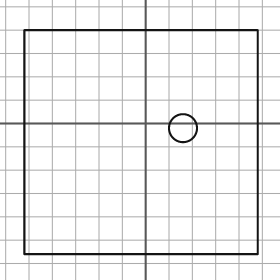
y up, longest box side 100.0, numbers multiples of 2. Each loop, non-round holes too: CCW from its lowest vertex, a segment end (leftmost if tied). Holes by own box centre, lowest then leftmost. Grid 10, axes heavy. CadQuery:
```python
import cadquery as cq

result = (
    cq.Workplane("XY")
    .moveTo(-52.0, -56.0)
    .lineTo(48.0, -56.0)
    .lineTo(48.0, 40.0)
    .lineTo(-52.0, 40.0)
    .close()
    .moveTo(16.0, -2.0)
    .circle(6.0)
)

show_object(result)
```